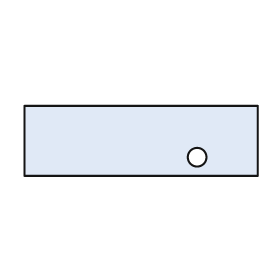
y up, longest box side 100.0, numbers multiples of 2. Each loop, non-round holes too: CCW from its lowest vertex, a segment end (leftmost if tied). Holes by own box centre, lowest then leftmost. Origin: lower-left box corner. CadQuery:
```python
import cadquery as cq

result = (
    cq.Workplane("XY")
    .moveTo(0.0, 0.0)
    .lineTo(100.0, 0.0)
    .lineTo(100.0, 30.0)
    .lineTo(0.0, 30.0)
    .close()
    .moveTo(74.0, 8.0)
    .circle(4.0)
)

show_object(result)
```